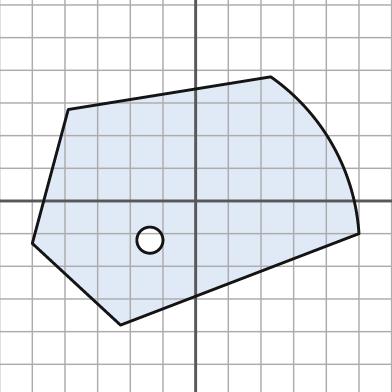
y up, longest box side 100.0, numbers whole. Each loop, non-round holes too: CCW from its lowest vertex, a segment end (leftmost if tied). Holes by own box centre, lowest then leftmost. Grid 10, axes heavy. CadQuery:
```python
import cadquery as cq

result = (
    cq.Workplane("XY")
    .moveTo(-23.0, -38.0)
    .lineTo(50.0, -10.0)
    .threePointArc((42.0, 17.0), (23.0, 38.0))
    .lineTo(-39.0, 28.0)
    .lineTo(-50.0, -13.0)
    .close()
    .moveTo(-14.0, -12.0)
    .circle(4.0)
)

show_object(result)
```